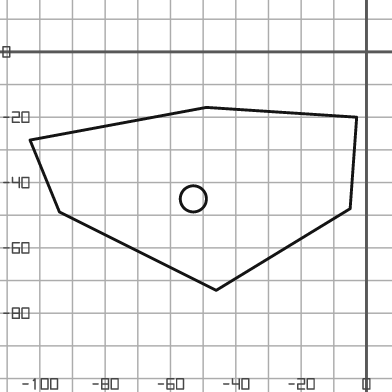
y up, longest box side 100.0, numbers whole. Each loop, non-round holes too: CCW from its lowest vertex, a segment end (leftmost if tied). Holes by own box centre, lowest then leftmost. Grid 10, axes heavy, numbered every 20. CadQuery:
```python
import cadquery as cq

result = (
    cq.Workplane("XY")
    .moveTo(-46.0, -73.0)
    .lineTo(-5.0, -48.0)
    .lineTo(-3.0, -20.0)
    .lineTo(-49.0, -17.0)
    .lineTo(-103.0, -27.0)
    .lineTo(-94.0, -49.0)
    .close()
    .moveTo(-53.0, -45.0)
    .circle(4.0)
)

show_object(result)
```